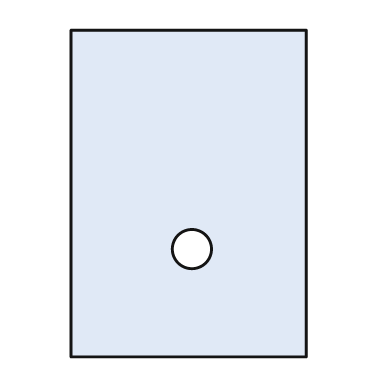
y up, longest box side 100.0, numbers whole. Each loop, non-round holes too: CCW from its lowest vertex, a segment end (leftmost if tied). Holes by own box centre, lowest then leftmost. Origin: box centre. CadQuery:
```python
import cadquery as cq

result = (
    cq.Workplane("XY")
    .moveTo(-36.0, -50.0)
    .lineTo(36.0, -50.0)
    .lineTo(36.0, 50.0)
    .lineTo(-36.0, 50.0)
    .close()
    .moveTo(1.0, -17.0)
    .circle(6.0)
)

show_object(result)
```